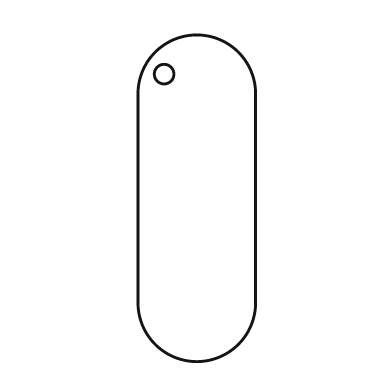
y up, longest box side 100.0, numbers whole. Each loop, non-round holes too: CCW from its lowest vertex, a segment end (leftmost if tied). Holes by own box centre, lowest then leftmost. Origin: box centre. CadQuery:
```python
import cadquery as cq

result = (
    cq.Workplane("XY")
    .moveTo(-18.0, -32.0)
    .threePointArc((0.0, -50.0), (18.0, -32.0))
    .lineTo(18.0, 32.0)
    .threePointArc((0.0, 50.0), (-18.0, 32.0))
    .close()
    .moveTo(-10.0, 38.0)
    .circle(3.0)
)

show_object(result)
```